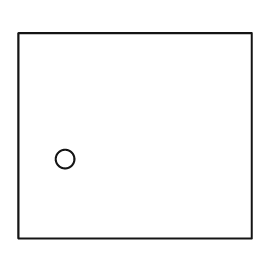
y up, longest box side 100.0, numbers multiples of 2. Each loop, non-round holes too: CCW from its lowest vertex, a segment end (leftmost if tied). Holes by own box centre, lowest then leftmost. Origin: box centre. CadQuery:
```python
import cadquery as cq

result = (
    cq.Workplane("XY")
    .moveTo(-50.0, -44.0)
    .lineTo(50.0, -44.0)
    .lineTo(50.0, 44.0)
    .lineTo(-50.0, 44.0)
    .close()
    .moveTo(-30.0, -10.0)
    .circle(4.0)
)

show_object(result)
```